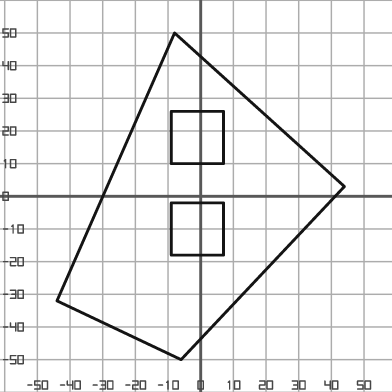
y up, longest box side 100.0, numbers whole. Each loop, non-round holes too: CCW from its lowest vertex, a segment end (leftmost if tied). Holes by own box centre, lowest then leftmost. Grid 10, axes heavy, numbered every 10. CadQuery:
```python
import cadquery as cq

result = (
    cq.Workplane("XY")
    .moveTo(-6.0, -50.0)
    .lineTo(44.0, 3.0)
    .lineTo(-8.0, 50.0)
    .lineTo(-44.0, -32.0)
    .close()
    .moveTo(-9.0, -18.0)
    .lineTo(7.0, -18.0)
    .lineTo(7.0, -2.0)
    .lineTo(-9.0, -2.0)
    .close()
    .moveTo(-9.0, 10.0)
    .lineTo(7.0, 10.0)
    .lineTo(7.0, 26.0)
    .lineTo(-9.0, 26.0)
    .close()
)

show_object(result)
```